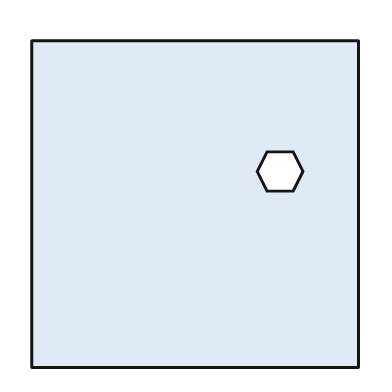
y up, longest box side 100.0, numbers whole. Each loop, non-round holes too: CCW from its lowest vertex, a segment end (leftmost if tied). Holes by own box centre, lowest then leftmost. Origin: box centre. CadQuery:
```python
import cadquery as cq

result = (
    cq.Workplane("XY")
    .moveTo(-50.0, -50.0)
    .lineTo(50.0, -50.0)
    .lineTo(50.0, 50.0)
    .lineTo(-50.0, 50.0)
    .close()
    .moveTo(22.0, 4.0)
    .lineTo(30.0, 4.0)
    .lineTo(33.0, 10.0)
    .lineTo(30.0, 16.0)
    .lineTo(22.0, 16.0)
    .lineTo(19.0, 10.0)
    .close()
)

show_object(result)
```